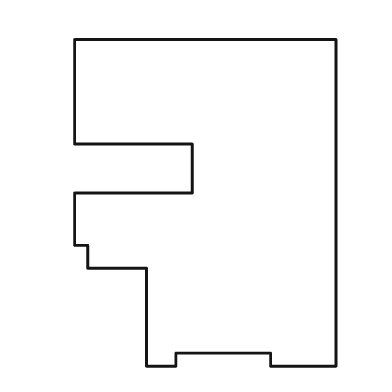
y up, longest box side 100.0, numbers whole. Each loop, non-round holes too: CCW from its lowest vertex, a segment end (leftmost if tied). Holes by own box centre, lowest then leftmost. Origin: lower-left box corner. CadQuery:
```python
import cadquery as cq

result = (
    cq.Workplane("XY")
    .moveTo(22.0, 0.0)
    .lineTo(31.0, 0.0)
    .lineTo(31.0, 4.0)
    .lineTo(60.0, 4.0)
    .lineTo(60.0, 0.0)
    .lineTo(80.0, 0.0)
    .lineTo(80.0, 100.0)
    .lineTo(0.0, 100.0)
    .lineTo(0.0, 68.0)
    .lineTo(36.0, 68.0)
    .lineTo(36.0, 53.0)
    .lineTo(0.0, 53.0)
    .lineTo(0.0, 37.0)
    .lineTo(4.0, 37.0)
    .lineTo(4.0, 30.0)
    .lineTo(22.0, 30.0)
    .close()
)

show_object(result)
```